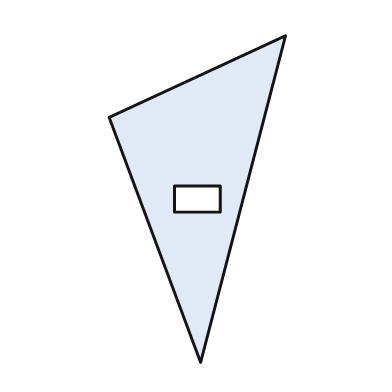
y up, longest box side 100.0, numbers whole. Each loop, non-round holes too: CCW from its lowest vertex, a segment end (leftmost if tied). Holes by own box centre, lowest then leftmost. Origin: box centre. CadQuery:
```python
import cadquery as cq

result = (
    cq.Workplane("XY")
    .moveTo(1.0, -50.0)
    .lineTo(27.0, 50.0)
    .lineTo(-27.0, 25.0)
    .close()
    .moveTo(-7.0, -4.0)
    .lineTo(7.0, -4.0)
    .lineTo(7.0, 4.0)
    .lineTo(-7.0, 4.0)
    .close()
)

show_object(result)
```